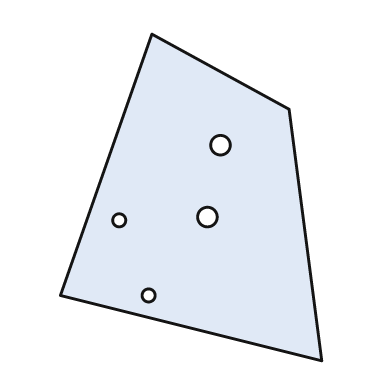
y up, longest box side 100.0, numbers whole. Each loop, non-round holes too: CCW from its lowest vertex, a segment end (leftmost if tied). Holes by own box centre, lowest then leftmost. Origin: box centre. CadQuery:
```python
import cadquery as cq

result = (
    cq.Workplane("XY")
    .moveTo(40.0, -50.0)
    .lineTo(30.0, 27.0)
    .lineTo(-12.0, 50.0)
    .lineTo(-40.0, -30.0)
    .close()
    .moveTo(-13.0, -30.0)
    .circle(2.0)
    .moveTo(-22.0, -7.0)
    .circle(2.0)
    .moveTo(5.0, -6.0)
    .circle(3.0)
    .moveTo(9.0, 16.0)
    .circle(3.0)
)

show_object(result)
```